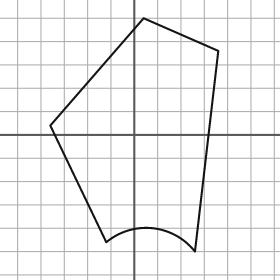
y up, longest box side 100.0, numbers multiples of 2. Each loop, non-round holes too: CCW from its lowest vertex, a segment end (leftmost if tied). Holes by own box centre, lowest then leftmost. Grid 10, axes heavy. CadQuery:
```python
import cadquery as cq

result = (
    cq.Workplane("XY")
    .moveTo(26.0, -50.0)
    .lineTo(36.0, 36.0)
    .lineTo(4.0, 50.0)
    .lineTo(-36.0, 4.0)
    .lineTo(-12.0, -46.0)
    .threePointArc((8.0, -40.0), (26.0, -50.0))
    .close()
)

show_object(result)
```